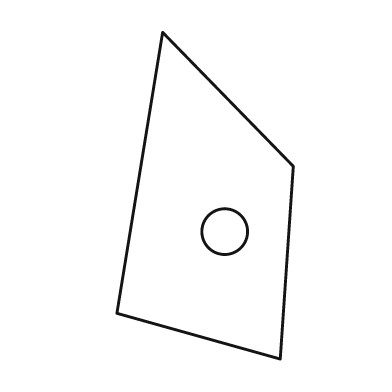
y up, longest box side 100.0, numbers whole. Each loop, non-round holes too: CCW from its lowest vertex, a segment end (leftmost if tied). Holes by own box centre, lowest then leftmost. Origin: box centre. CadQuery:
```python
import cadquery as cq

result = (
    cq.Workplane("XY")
    .moveTo(23.0, -50.0)
    .lineTo(27.0, 9.0)
    .lineTo(-13.0, 50.0)
    .lineTo(-27.0, -36.0)
    .close()
    .moveTo(6.0, -11.0)
    .circle(7.0)
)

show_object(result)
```